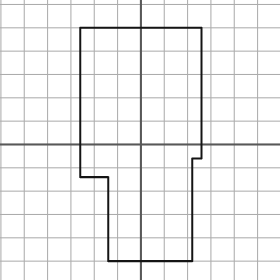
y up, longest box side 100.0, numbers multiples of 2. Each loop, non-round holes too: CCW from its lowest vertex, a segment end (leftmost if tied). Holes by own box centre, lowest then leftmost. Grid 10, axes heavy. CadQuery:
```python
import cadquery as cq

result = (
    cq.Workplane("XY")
    .moveTo(-14.0, -50.0)
    .lineTo(22.0, -50.0)
    .lineTo(22.0, -6.0)
    .lineTo(26.0, -6.0)
    .lineTo(26.0, 50.0)
    .lineTo(-26.0, 50.0)
    .lineTo(-26.0, -14.0)
    .lineTo(-14.0, -14.0)
    .close()
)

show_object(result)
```